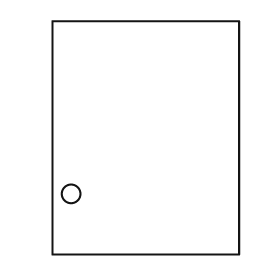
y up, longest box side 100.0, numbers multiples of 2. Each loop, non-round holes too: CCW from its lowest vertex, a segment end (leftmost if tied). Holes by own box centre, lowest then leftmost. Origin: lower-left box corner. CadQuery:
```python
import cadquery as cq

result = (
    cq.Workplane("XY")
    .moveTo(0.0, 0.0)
    .lineTo(80.0, 0.0)
    .lineTo(80.0, 100.0)
    .lineTo(0.0, 100.0)
    .close()
    .moveTo(8.0, 26.0)
    .circle(4.0)
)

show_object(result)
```